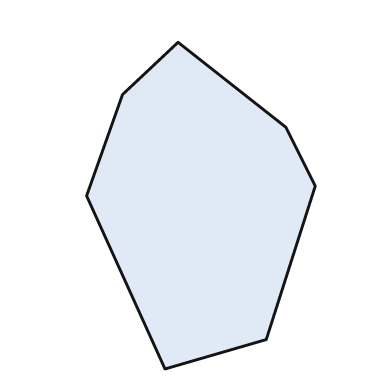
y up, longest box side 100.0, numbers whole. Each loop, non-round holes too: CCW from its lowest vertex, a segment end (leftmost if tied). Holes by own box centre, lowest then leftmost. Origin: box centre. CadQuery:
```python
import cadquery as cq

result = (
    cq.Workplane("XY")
    .moveTo(-11.0, -50.0)
    .lineTo(20.0, -41.0)
    .lineTo(35.0, 6.0)
    .lineTo(26.0, 24.0)
    .lineTo(-7.0, 50.0)
    .lineTo(-24.0, 34.0)
    .lineTo(-35.0, 3.0)
    .close()
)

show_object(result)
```